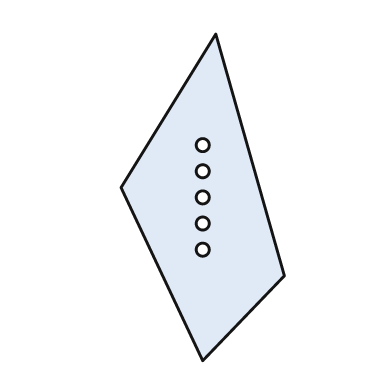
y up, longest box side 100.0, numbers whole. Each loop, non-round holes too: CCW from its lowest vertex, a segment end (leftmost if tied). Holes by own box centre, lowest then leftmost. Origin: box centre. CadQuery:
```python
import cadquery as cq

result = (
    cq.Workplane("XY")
    .moveTo(0.0, -50.0)
    .lineTo(25.0, -24.0)
    .lineTo(4.0, 50.0)
    .lineTo(-25.0, 3.0)
    .close()
    .moveTo(0.0, -16.0)
    .circle(2.0)
    .moveTo(0.0, -8.0)
    .circle(2.0)
    .moveTo(0.0, 0.0)
    .circle(2.0)
    .moveTo(0.0, 8.0)
    .circle(2.0)
    .moveTo(0.0, 16.0)
    .circle(2.0)
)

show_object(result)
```